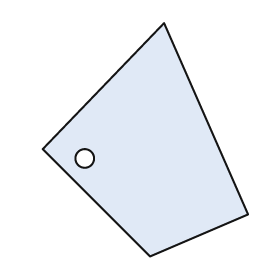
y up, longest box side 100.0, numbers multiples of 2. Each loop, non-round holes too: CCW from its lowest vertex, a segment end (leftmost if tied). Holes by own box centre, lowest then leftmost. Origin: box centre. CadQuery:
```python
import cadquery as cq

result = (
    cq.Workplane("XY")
    .moveTo(2.0, -50.0)
    .lineTo(44.0, -32.0)
    .lineTo(8.0, 50.0)
    .lineTo(-44.0, -4.0)
    .close()
    .moveTo(-26.0, -8.0)
    .circle(4.0)
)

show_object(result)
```